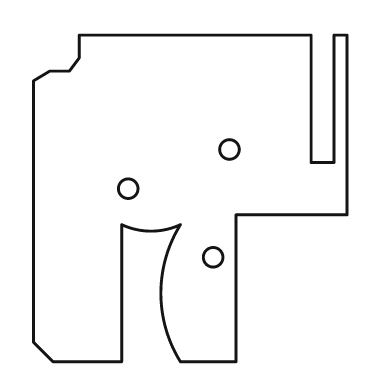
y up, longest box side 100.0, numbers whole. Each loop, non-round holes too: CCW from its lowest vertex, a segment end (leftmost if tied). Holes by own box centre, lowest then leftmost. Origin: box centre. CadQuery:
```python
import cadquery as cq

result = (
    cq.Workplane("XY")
    .moveTo(-42.0, -50.0)
    .lineTo(-21.0, -50.0)
    .lineTo(-21.0, -8.0)
    .threePointArc((-12.0, -10.0), (-3.0, -8.0))
    .threePointArc((-9.0, -29.0), (-3.0, -50.0))
    .lineTo(14.0, -50.0)
    .lineTo(14.0, -5.0)
    .lineTo(48.0, -5.0)
    .lineTo(48.0, 50.0)
    .lineTo(44.0, 50.0)
    .lineTo(44.0, 11.0)
    .lineTo(37.0, 11.0)
    .lineTo(37.0, 50.0)
    .lineTo(-34.0, 50.0)
    .lineTo(-34.0, 43.0)
    .lineTo(-37.0, 39.0)
    .lineTo(-43.0, 39.0)
    .lineTo(-48.0, 36.0)
    .lineTo(-48.0, -44.0)
    .close()
    .moveTo(7.0, -18.0)
    .circle(3.0)
    .moveTo(-19.0, 3.0)
    .circle(3.0)
    .moveTo(12.0, 15.0)
    .circle(3.0)
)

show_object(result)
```